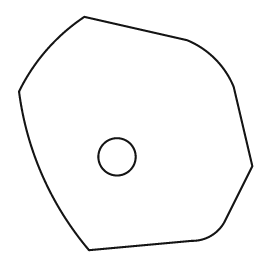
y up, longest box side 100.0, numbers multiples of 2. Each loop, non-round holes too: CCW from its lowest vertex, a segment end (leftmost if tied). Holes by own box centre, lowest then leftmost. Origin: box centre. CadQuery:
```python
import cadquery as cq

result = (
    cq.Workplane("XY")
    .moveTo(-20.0, -50.0)
    .lineTo(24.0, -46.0)
    .threePointArc((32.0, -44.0), (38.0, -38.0))
    .lineTo(50.0, -14.0)
    .lineTo(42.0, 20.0)
    .threePointArc((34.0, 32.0), (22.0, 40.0))
    .lineTo(-22.0, 50.0)
    .threePointArc((-38.0, 36.0), (-50.0, 18.0))
    .threePointArc((-40.0, -18.0), (-20.0, -50.0))
    .close()
    .moveTo(-8.0, -10.0)
    .circle(8.0)
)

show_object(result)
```